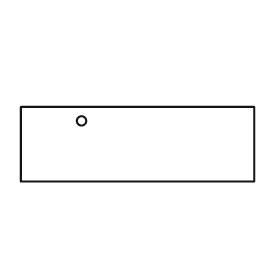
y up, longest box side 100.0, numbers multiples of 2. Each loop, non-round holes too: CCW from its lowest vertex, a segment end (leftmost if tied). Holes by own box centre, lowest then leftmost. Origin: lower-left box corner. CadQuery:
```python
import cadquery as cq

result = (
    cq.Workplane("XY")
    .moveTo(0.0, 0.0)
    .lineTo(100.0, 0.0)
    .lineTo(100.0, 32.0)
    .lineTo(0.0, 32.0)
    .close()
    .moveTo(26.0, 26.0)
    .circle(2.0)
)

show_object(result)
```